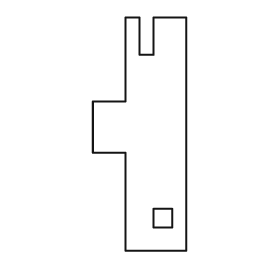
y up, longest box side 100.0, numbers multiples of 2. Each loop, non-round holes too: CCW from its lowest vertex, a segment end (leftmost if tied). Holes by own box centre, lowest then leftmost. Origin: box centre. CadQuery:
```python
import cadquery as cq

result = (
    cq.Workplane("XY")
    .moveTo(-6.0, -50.0)
    .lineTo(20.0, -50.0)
    .lineTo(20.0, 50.0)
    .lineTo(6.0, 50.0)
    .lineTo(6.0, 34.0)
    .lineTo(0.0, 34.0)
    .lineTo(0.0, 50.0)
    .lineTo(-6.0, 50.0)
    .lineTo(-6.0, 14.0)
    .lineTo(-20.0, 14.0)
    .lineTo(-20.0, -8.0)
    .lineTo(-6.0, -8.0)
    .close()
    .moveTo(6.0, -40.0)
    .lineTo(14.0, -40.0)
    .lineTo(14.0, -32.0)
    .lineTo(6.0, -32.0)
    .close()
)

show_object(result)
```